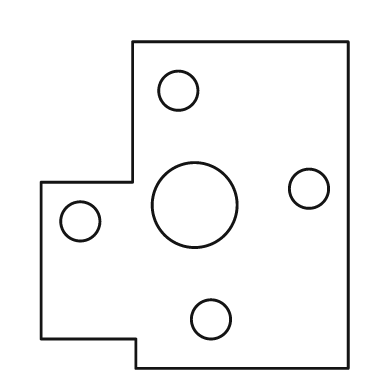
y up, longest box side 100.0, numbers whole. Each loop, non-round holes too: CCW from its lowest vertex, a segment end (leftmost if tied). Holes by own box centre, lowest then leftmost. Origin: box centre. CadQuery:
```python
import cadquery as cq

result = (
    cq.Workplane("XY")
    .moveTo(-18.0, -50.0)
    .lineTo(47.0, -50.0)
    .lineTo(47.0, 50.0)
    .lineTo(-19.0, 50.0)
    .lineTo(-19.0, 7.0)
    .lineTo(-47.0, 7.0)
    .lineTo(-47.0, -41.0)
    .lineTo(-18.0, -41.0)
    .close()
    .moveTo(5.0, -35.0)
    .circle(6.0)
    .moveTo(-35.0, -5.0)
    .circle(6.0)
    .moveTo(0.0, 0.0)
    .circle(13.0)
    .moveTo(35.0, 5.0)
    .circle(6.0)
    .moveTo(-5.0, 35.0)
    .circle(6.0)
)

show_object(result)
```